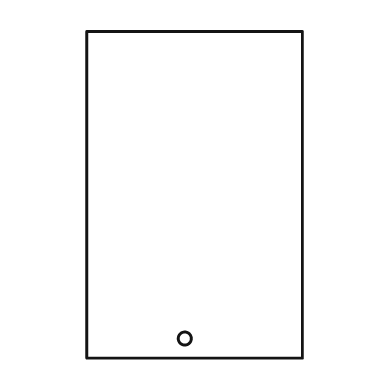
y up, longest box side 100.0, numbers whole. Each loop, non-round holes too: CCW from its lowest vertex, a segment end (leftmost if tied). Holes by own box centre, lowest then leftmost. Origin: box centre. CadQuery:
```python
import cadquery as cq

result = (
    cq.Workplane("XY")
    .moveTo(-33.0, -50.0)
    .lineTo(33.0, -50.0)
    .lineTo(33.0, 50.0)
    .lineTo(-33.0, 50.0)
    .close()
    .moveTo(-3.0, -44.0)
    .circle(2.0)
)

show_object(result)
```